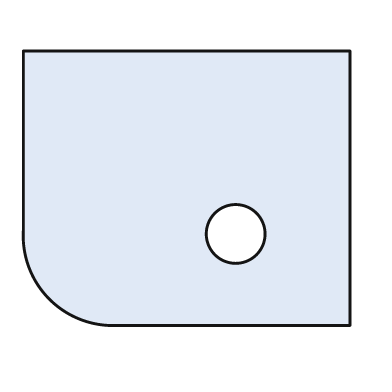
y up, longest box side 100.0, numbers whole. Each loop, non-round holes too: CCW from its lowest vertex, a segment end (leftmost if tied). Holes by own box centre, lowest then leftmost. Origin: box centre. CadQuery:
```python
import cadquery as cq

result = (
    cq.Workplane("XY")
    .moveTo(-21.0, -42.0)
    .lineTo(50.0, -42.0)
    .lineTo(50.0, 42.0)
    .lineTo(-50.0, 42.0)
    .lineTo(-50.0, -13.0)
    .threePointArc((-42.0, -34.0), (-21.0, -42.0))
    .close()
    .moveTo(15.0, -14.0)
    .circle(9.0)
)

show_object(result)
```